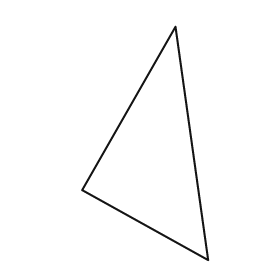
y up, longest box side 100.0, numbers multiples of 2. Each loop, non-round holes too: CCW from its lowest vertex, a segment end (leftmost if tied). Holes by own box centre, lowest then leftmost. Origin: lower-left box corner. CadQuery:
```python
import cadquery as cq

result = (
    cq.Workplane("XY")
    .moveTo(54.0, 0.0)
    .lineTo(40.0, 100.0)
    .lineTo(0.0, 30.0)
    .close()
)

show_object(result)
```